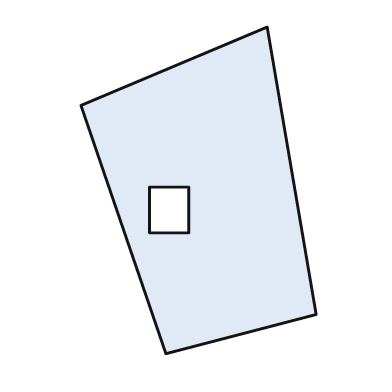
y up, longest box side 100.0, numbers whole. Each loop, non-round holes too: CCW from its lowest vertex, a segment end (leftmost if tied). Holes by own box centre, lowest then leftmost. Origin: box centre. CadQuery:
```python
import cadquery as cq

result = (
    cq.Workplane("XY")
    .moveTo(-10.0, -50.0)
    .lineTo(36.0, -38.0)
    .lineTo(21.0, 50.0)
    .lineTo(-36.0, 26.0)
    .close()
    .moveTo(-15.0, -13.0)
    .lineTo(-3.0, -13.0)
    .lineTo(-3.0, 1.0)
    .lineTo(-15.0, 1.0)
    .close()
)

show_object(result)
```